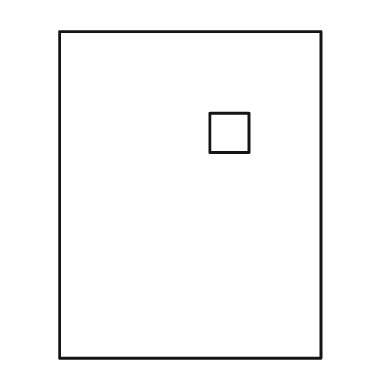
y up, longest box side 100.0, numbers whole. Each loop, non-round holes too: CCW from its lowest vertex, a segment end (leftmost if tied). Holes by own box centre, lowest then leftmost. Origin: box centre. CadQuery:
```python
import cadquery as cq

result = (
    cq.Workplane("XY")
    .moveTo(-40.0, -50.0)
    .lineTo(40.0, -50.0)
    .lineTo(40.0, 50.0)
    .lineTo(-40.0, 50.0)
    .close()
    .moveTo(6.0, 13.0)
    .lineTo(18.0, 13.0)
    .lineTo(18.0, 25.0)
    .lineTo(6.0, 25.0)
    .close()
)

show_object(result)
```